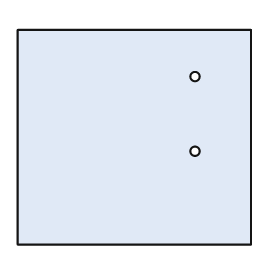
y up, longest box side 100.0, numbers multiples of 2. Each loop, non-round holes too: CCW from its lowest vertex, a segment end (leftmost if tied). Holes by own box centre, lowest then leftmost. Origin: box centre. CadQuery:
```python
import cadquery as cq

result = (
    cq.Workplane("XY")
    .moveTo(-50.0, -46.0)
    .lineTo(50.0, -46.0)
    .lineTo(50.0, 46.0)
    .lineTo(-50.0, 46.0)
    .close()
    .moveTo(26.0, -6.0)
    .circle(2.0)
    .moveTo(26.0, 26.0)
    .circle(2.0)
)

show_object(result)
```